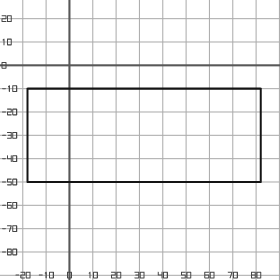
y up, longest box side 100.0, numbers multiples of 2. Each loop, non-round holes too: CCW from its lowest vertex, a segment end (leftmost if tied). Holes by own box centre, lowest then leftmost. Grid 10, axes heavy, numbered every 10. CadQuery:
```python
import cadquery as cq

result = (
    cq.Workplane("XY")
    .moveTo(-18.0, -50.0)
    .lineTo(82.0, -50.0)
    .lineTo(82.0, -10.0)
    .lineTo(-18.0, -10.0)
    .close()
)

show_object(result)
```